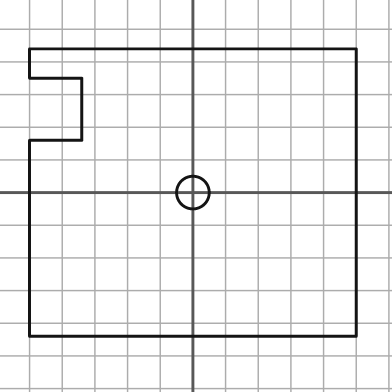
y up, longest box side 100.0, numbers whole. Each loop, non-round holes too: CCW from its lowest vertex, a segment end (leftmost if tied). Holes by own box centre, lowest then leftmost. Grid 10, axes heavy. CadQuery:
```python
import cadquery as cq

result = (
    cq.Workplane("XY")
    .moveTo(-50.0, -44.0)
    .lineTo(50.0, -44.0)
    .lineTo(50.0, 44.0)
    .lineTo(-50.0, 44.0)
    .lineTo(-50.0, 35.0)
    .lineTo(-34.0, 35.0)
    .lineTo(-34.0, 16.0)
    .lineTo(-50.0, 16.0)
    .close()
    .moveTo(0.0, 0.0)
    .circle(5.0)
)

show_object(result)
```